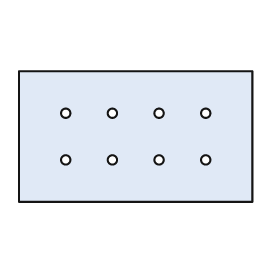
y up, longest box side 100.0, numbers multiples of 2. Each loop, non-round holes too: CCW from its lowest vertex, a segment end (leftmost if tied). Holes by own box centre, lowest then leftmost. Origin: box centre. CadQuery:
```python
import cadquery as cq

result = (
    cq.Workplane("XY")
    .moveTo(-50.0, -28.0)
    .lineTo(50.0, -28.0)
    .lineTo(50.0, 28.0)
    .lineTo(-50.0, 28.0)
    .close()
    .moveTo(-30.0, -10.0)
    .circle(2.0)
    .moveTo(-10.0, -10.0)
    .circle(2.0)
    .moveTo(10.0, -10.0)
    .circle(2.0)
    .moveTo(30.0, -10.0)
    .circle(2.0)
    .moveTo(-30.0, 10.0)
    .circle(2.0)
    .moveTo(-10.0, 10.0)
    .circle(2.0)
    .moveTo(10.0, 10.0)
    .circle(2.0)
    .moveTo(30.0, 10.0)
    .circle(2.0)
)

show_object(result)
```